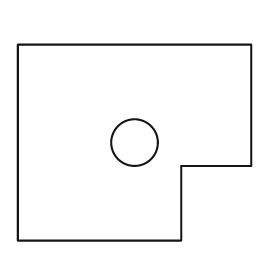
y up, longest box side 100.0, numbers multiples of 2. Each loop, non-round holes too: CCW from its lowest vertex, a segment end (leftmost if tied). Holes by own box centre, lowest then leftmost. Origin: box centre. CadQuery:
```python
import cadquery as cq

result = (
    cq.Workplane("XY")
    .moveTo(-50.0, -42.0)
    .lineTo(20.0, -42.0)
    .lineTo(20.0, -10.0)
    .lineTo(50.0, -10.0)
    .lineTo(50.0, 42.0)
    .lineTo(-50.0, 42.0)
    .close()
    .moveTo(0.0, 0.0)
    .circle(10.0)
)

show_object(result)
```